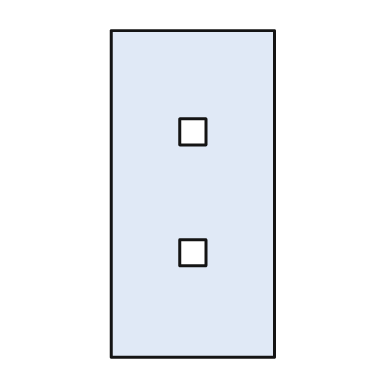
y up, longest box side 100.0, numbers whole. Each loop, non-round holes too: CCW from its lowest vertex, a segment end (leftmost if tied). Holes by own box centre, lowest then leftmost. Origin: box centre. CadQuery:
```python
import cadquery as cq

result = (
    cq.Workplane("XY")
    .moveTo(-25.0, -50.0)
    .lineTo(25.0, -50.0)
    .lineTo(25.0, 50.0)
    .lineTo(-25.0, 50.0)
    .close()
    .moveTo(-4.0, -22.0)
    .lineTo(4.0, -22.0)
    .lineTo(4.0, -14.0)
    .lineTo(-4.0, -14.0)
    .close()
    .moveTo(-4.0, 15.0)
    .lineTo(4.0, 15.0)
    .lineTo(4.0, 23.0)
    .lineTo(-4.0, 23.0)
    .close()
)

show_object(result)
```